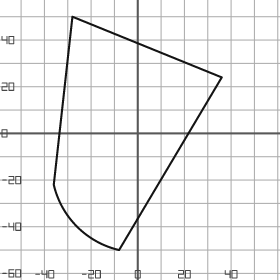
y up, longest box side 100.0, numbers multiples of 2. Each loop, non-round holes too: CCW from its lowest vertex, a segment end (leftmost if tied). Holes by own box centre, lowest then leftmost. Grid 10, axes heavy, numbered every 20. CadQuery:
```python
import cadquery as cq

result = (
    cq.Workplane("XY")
    .moveTo(-8.0, -50.0)
    .lineTo(36.0, 24.0)
    .lineTo(-28.0, 50.0)
    .lineTo(-36.0, -22.0)
    .threePointArc((-26.0, -40.0), (-8.0, -50.0))
    .close()
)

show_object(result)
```